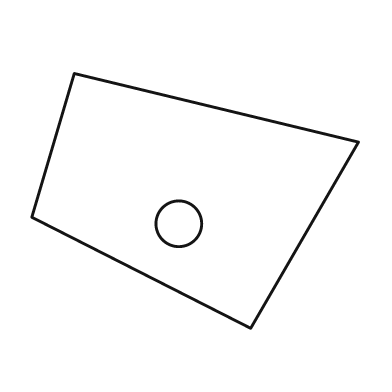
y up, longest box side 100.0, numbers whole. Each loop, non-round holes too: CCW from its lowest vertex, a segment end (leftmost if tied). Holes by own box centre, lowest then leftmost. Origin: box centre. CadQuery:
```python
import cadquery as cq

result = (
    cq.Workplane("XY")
    .moveTo(17.0, -39.0)
    .lineTo(50.0, 18.0)
    .lineTo(-37.0, 39.0)
    .lineTo(-50.0, -5.0)
    .close()
    .moveTo(-5.0, -7.0)
    .circle(7.0)
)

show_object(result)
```